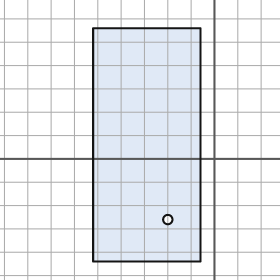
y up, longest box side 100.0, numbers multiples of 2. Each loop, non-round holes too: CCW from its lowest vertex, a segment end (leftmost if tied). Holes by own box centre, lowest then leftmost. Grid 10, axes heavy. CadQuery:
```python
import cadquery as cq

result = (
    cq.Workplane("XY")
    .moveTo(-52.0, -44.0)
    .lineTo(-6.0, -44.0)
    .lineTo(-6.0, 56.0)
    .lineTo(-52.0, 56.0)
    .close()
    .moveTo(-20.0, -26.0)
    .circle(2.0)
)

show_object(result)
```